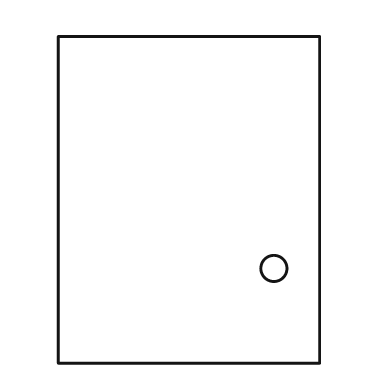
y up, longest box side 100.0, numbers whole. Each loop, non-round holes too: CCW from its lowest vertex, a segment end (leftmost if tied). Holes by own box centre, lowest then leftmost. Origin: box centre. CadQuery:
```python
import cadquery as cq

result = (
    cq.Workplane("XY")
    .moveTo(-40.0, -50.0)
    .lineTo(40.0, -50.0)
    .lineTo(40.0, 50.0)
    .lineTo(-40.0, 50.0)
    .close()
    .moveTo(26.0, -21.0)
    .circle(4.0)
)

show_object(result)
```